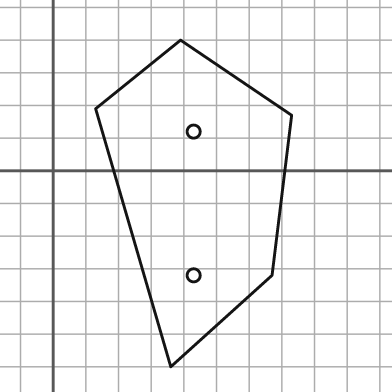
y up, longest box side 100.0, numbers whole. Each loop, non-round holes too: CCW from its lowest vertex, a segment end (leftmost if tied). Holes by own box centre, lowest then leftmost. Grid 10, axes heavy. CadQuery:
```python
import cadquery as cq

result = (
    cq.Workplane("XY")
    .moveTo(36.0, -60.0)
    .lineTo(67.0, -32.0)
    .lineTo(73.0, 17.0)
    .lineTo(39.0, 40.0)
    .lineTo(13.0, 19.0)
    .close()
    .moveTo(43.0, -32.0)
    .circle(2.0)
    .moveTo(43.0, 12.0)
    .circle(2.0)
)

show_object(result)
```